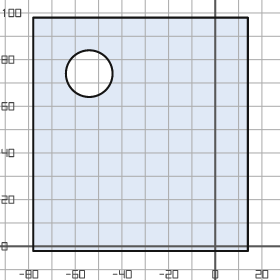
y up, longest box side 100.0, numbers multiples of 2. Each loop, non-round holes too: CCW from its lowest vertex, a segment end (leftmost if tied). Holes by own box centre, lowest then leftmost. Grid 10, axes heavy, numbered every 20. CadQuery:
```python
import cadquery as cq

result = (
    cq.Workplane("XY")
    .moveTo(-78.0, -2.0)
    .lineTo(14.0, -2.0)
    .lineTo(14.0, 98.0)
    .lineTo(-78.0, 98.0)
    .close()
    .moveTo(-54.0, 74.0)
    .circle(10.0)
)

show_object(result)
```